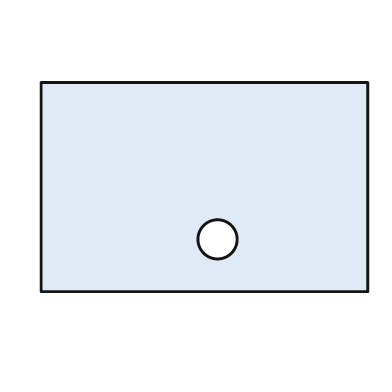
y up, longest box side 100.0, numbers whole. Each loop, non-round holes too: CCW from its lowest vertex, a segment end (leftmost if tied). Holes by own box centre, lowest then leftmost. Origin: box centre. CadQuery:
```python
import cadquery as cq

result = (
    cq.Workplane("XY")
    .moveTo(-50.0, -32.0)
    .lineTo(50.0, -32.0)
    .lineTo(50.0, 32.0)
    .lineTo(-50.0, 32.0)
    .close()
    .moveTo(4.0, -16.0)
    .circle(6.0)
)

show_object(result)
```